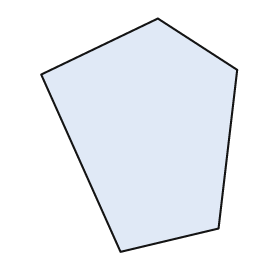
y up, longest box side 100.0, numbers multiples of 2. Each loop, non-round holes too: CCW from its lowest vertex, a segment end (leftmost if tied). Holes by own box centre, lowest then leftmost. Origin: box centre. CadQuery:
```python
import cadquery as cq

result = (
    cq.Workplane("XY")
    .moveTo(-8.0, -50.0)
    .lineTo(34.0, -40.0)
    .lineTo(42.0, 28.0)
    .lineTo(8.0, 50.0)
    .lineTo(-42.0, 26.0)
    .close()
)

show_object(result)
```